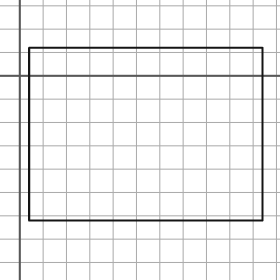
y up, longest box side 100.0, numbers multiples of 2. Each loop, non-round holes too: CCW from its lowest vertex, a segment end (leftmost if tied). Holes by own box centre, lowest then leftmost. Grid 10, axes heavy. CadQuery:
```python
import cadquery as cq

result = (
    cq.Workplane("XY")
    .moveTo(4.0, -62.0)
    .lineTo(104.0, -62.0)
    .lineTo(104.0, 12.0)
    .lineTo(4.0, 12.0)
    .close()
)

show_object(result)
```